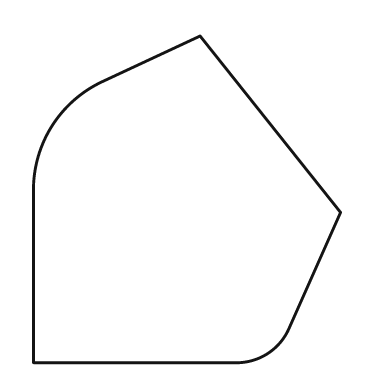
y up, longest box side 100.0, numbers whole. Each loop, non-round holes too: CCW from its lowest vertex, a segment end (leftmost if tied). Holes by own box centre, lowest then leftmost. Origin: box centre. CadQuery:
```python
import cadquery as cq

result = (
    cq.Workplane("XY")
    .moveTo(-47.0, -50.0)
    .lineTo(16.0, -50.0)
    .threePointArc((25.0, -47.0), (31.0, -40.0))
    .lineTo(47.0, -4.0)
    .lineTo(4.0, 50.0)
    .lineTo(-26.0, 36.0)
    .threePointArc((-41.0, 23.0), (-47.0, 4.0))
    .close()
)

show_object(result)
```